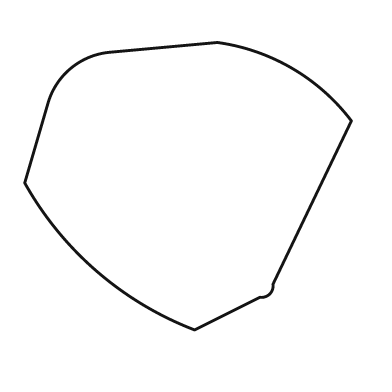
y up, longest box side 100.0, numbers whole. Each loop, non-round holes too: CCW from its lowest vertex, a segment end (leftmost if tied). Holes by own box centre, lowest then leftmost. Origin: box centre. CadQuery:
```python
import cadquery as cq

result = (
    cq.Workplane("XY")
    .moveTo(2.0, -44.0)
    .lineTo(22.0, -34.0)
    .threePointArc((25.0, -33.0), (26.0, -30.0))
    .lineTo(50.0, 20.0)
    .threePointArc((32.0, 36.0), (9.0, 44.0))
    .lineTo(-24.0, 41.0)
    .threePointArc((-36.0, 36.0), (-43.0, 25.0))
    .lineTo(-50.0, 1.0)
    .threePointArc((-28.0, -26.0), (2.0, -44.0))
    .close()
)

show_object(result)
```